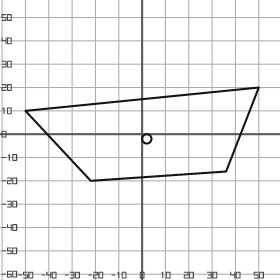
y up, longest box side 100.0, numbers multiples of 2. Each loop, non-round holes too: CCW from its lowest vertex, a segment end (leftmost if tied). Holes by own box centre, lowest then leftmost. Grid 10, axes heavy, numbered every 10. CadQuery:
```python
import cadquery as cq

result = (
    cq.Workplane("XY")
    .moveTo(-22.0, -20.0)
    .lineTo(36.0, -16.0)
    .lineTo(50.0, 20.0)
    .lineTo(-50.0, 10.0)
    .close()
    .moveTo(2.0, -2.0)
    .circle(2.0)
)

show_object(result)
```